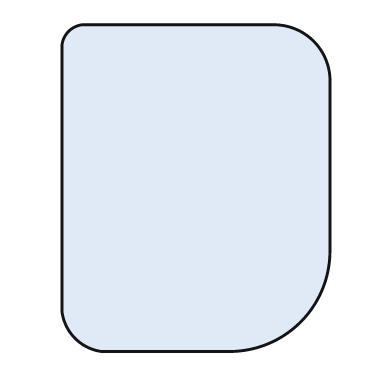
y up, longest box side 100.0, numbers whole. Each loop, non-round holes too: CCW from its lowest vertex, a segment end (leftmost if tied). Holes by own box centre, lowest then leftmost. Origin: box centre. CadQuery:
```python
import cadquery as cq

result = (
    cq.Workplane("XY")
    .moveTo(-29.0, -50.0)
    .lineTo(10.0, -50.0)
    .threePointArc((32.0, -41.0), (41.0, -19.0))
    .lineTo(41.0, 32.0)
    .threePointArc((36.0, 45.0), (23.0, 50.0))
    .lineTo(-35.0, 50.0)
    .threePointArc((-39.0, 48.0), (-41.0, 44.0))
    .lineTo(-41.0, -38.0)
    .threePointArc((-37.0, -46.0), (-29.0, -50.0))
    .close()
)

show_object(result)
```